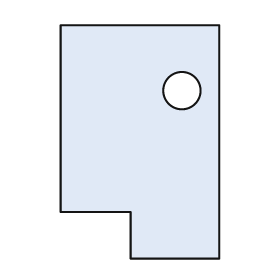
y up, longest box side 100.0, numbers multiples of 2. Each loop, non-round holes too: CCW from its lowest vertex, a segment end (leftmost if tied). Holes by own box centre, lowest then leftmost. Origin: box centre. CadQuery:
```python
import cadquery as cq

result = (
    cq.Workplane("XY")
    .moveTo(-4.0, -50.0)
    .lineTo(34.0, -50.0)
    .lineTo(34.0, 50.0)
    .lineTo(-34.0, 50.0)
    .lineTo(-34.0, -30.0)
    .lineTo(-4.0, -30.0)
    .close()
    .moveTo(18.0, 22.0)
    .circle(8.0)
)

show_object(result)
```